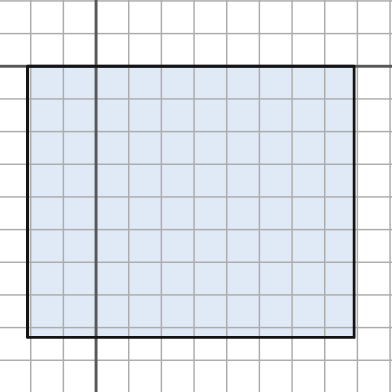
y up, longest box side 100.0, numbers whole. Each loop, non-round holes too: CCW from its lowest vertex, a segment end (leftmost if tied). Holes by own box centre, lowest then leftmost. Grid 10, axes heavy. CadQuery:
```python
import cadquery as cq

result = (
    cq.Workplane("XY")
    .moveTo(-21.0, -83.0)
    .lineTo(79.0, -83.0)
    .lineTo(79.0, 0.0)
    .lineTo(-21.0, 0.0)
    .close()
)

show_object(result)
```